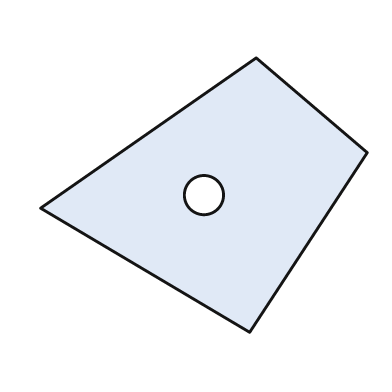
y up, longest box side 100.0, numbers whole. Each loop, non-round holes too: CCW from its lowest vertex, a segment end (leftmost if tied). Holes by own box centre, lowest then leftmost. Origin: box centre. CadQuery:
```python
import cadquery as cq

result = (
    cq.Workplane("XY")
    .moveTo(14.0, -42.0)
    .lineTo(50.0, 13.0)
    .lineTo(16.0, 42.0)
    .lineTo(-50.0, -4.0)
    .close()
    .moveTo(0.0, 0.0)
    .circle(6.0)
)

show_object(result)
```